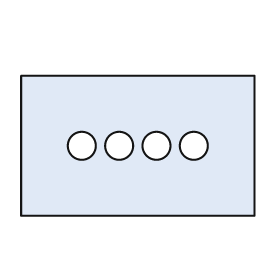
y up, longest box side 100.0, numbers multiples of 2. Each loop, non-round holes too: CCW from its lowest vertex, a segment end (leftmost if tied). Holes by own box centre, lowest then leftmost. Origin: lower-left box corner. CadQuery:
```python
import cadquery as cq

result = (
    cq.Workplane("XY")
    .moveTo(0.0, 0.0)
    .lineTo(100.0, 0.0)
    .lineTo(100.0, 60.0)
    .lineTo(0.0, 60.0)
    .close()
    .moveTo(26.0, 30.0)
    .circle(6.0)
    .moveTo(42.0, 30.0)
    .circle(6.0)
    .moveTo(58.0, 30.0)
    .circle(6.0)
    .moveTo(74.0, 30.0)
    .circle(6.0)
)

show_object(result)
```